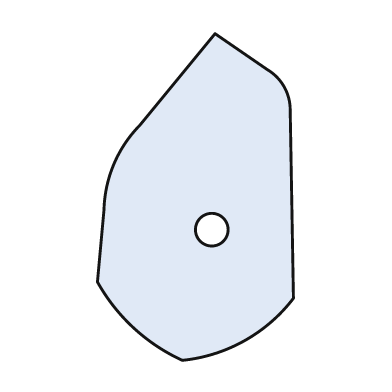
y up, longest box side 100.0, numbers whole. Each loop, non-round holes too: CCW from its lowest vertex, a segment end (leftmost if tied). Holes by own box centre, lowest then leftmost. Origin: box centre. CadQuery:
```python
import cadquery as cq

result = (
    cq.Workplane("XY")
    .moveTo(-4.0, -50.0)
    .threePointArc((15.0, -44.0), (30.0, -31.0))
    .lineTo(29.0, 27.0)
    .threePointArc((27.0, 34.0), (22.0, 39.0))
    .lineTo(6.0, 50.0)
    .lineTo(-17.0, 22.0)
    .threePointArc((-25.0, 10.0), (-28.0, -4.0))
    .lineTo(-30.0, -26.0)
    .threePointArc((-19.0, -40.0), (-4.0, -50.0))
    .close()
    .moveTo(5.0, -10.0)
    .circle(5.0)
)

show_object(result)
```